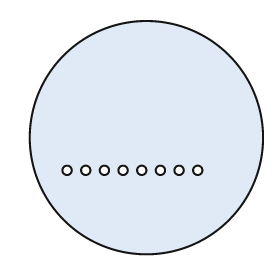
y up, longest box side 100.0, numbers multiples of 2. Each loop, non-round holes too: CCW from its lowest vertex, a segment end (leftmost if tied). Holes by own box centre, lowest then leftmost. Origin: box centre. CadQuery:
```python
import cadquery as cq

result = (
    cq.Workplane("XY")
    .moveTo(0.0, 0.0)
    .circle(50.0)
    .moveTo(-34.0, -14.0)
    .circle(2.0)
    .moveTo(-26.0, -14.0)
    .circle(2.0)
    .moveTo(-18.0, -14.0)
    .circle(2.0)
    .moveTo(-10.0, -14.0)
    .circle(2.0)
    .moveTo(-2.0, -14.0)
    .circle(2.0)
    .moveTo(6.0, -14.0)
    .circle(2.0)
    .moveTo(14.0, -14.0)
    .circle(2.0)
    .moveTo(22.0, -14.0)
    .circle(2.0)
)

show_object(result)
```